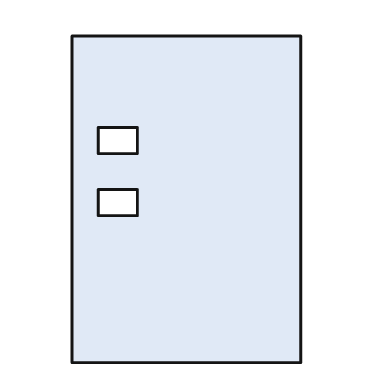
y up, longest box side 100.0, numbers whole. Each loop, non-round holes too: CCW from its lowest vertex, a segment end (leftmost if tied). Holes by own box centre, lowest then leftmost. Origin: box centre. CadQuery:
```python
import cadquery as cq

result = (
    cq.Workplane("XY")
    .moveTo(-35.0, -50.0)
    .lineTo(35.0, -50.0)
    .lineTo(35.0, 50.0)
    .lineTo(-35.0, 50.0)
    .close()
    .moveTo(-27.0, -5.0)
    .lineTo(-15.0, -5.0)
    .lineTo(-15.0, 3.0)
    .lineTo(-27.0, 3.0)
    .close()
    .moveTo(-27.0, 14.0)
    .lineTo(-15.0, 14.0)
    .lineTo(-15.0, 22.0)
    .lineTo(-27.0, 22.0)
    .close()
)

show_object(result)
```